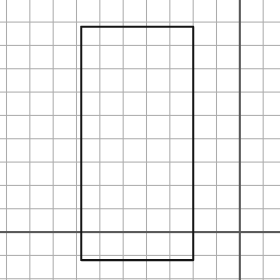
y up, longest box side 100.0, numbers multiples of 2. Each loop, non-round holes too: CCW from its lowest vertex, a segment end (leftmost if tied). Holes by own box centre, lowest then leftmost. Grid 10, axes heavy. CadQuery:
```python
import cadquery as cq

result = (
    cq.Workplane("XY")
    .moveTo(-68.0, -12.0)
    .lineTo(-20.0, -12.0)
    .lineTo(-20.0, 88.0)
    .lineTo(-68.0, 88.0)
    .close()
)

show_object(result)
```